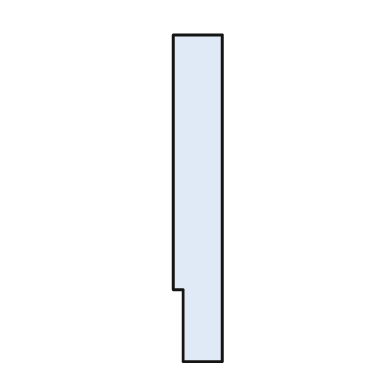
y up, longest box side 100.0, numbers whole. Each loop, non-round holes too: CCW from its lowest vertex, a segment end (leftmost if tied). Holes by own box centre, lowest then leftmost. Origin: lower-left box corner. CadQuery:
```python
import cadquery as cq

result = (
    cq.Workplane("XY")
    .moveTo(3.0, 0.0)
    .lineTo(15.0, 0.0)
    .lineTo(15.0, 100.0)
    .lineTo(0.0, 100.0)
    .lineTo(0.0, 22.0)
    .lineTo(3.0, 22.0)
    .close()
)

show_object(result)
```